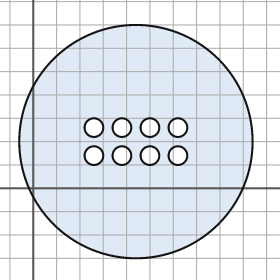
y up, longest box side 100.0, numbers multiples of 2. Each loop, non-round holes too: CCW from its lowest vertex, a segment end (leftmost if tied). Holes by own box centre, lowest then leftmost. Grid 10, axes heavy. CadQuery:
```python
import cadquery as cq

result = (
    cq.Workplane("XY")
    .moveTo(44.0, 20.0)
    .circle(50.0)
    .moveTo(26.0, 14.0)
    .circle(4.0)
    .moveTo(38.0, 14.0)
    .circle(4.0)
    .moveTo(50.0, 14.0)
    .circle(4.0)
    .moveTo(62.0, 14.0)
    .circle(4.0)
    .moveTo(26.0, 26.0)
    .circle(4.0)
    .moveTo(38.0, 26.0)
    .circle(4.0)
    .moveTo(50.0, 26.0)
    .circle(4.0)
    .moveTo(62.0, 26.0)
    .circle(4.0)
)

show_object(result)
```